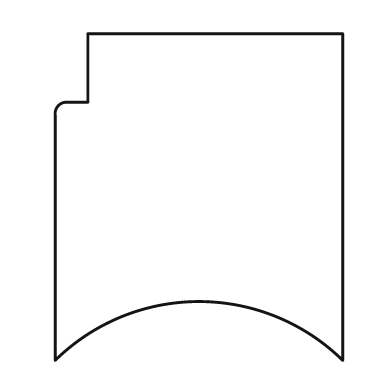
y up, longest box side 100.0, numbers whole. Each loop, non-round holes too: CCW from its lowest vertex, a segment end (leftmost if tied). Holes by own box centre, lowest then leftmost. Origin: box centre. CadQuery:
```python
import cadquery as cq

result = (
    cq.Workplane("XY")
    .moveTo(-44.0, -50.0)
    .threePointArc((0.0, -32.0), (44.0, -50.0))
    .lineTo(44.0, 50.0)
    .lineTo(-34.0, 50.0)
    .lineTo(-34.0, 29.0)
    .lineTo(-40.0, 29.0)
    .threePointArc((-43.0, 28.0), (-44.0, 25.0))
    .close()
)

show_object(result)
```